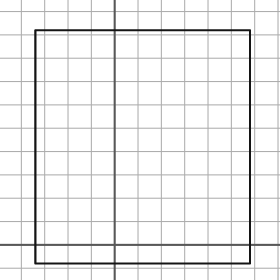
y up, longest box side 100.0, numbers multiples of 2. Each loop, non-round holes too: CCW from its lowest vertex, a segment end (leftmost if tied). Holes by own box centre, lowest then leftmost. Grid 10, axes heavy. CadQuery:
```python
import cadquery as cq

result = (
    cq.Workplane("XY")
    .moveTo(-34.0, -8.0)
    .lineTo(58.0, -8.0)
    .lineTo(58.0, 92.0)
    .lineTo(-34.0, 92.0)
    .close()
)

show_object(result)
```